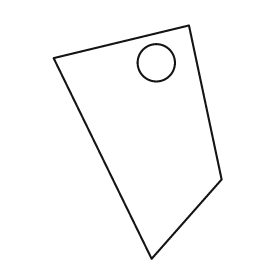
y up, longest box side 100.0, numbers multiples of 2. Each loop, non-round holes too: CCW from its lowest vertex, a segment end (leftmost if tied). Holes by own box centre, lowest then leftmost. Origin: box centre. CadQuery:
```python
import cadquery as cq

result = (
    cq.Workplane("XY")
    .moveTo(6.0, -50.0)
    .lineTo(36.0, -16.0)
    .lineTo(22.0, 50.0)
    .lineTo(-36.0, 36.0)
    .close()
    .moveTo(8.0, 34.0)
    .circle(8.0)
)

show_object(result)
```